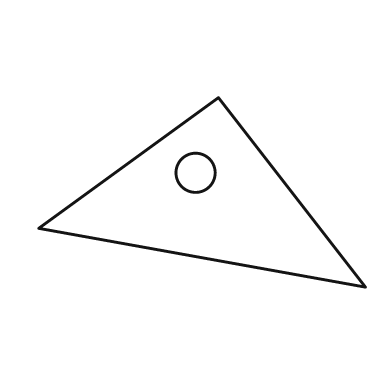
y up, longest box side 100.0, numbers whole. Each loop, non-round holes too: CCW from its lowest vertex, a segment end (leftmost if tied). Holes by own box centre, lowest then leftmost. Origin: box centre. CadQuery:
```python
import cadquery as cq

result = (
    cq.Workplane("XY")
    .moveTo(50.0, -29.0)
    .lineTo(5.0, 29.0)
    .lineTo(-50.0, -11.0)
    .close()
    .moveTo(-2.0, 6.0)
    .circle(6.0)
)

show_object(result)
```